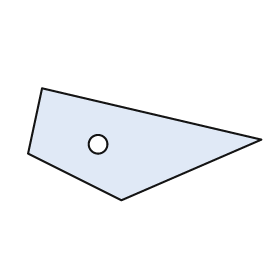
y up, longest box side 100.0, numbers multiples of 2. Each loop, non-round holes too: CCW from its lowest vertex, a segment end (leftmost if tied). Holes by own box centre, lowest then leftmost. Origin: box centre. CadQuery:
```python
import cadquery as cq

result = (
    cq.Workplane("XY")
    .moveTo(-10.0, -24.0)
    .lineTo(50.0, 2.0)
    .lineTo(-44.0, 24.0)
    .lineTo(-50.0, -4.0)
    .close()
    .moveTo(-20.0, 0.0)
    .circle(4.0)
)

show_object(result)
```